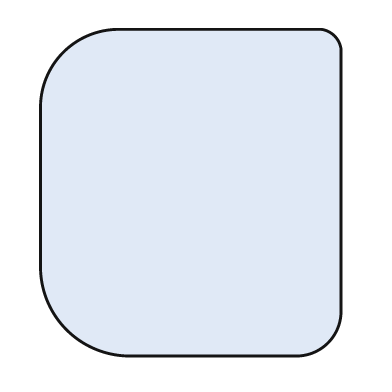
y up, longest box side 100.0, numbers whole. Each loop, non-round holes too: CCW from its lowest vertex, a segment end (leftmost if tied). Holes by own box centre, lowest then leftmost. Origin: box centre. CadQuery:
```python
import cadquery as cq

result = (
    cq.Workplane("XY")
    .moveTo(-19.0, -50.0)
    .lineTo(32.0, -50.0)
    .threePointArc((42.0, -46.0), (46.0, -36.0))
    .lineTo(46.0, 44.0)
    .threePointArc((44.0, 48.0), (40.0, 50.0))
    .lineTo(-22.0, 50.0)
    .threePointArc((-39.0, 43.0), (-46.0, 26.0))
    .lineTo(-46.0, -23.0)
    .threePointArc((-38.0, -42.0), (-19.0, -50.0))
    .close()
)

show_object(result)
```